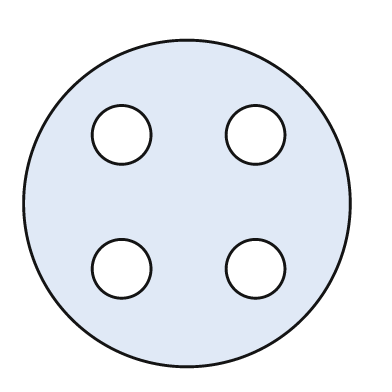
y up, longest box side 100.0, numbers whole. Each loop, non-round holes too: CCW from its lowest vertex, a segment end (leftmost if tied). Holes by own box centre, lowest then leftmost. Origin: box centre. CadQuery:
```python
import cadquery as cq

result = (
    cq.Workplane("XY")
    .moveTo(0.0, 0.0)
    .circle(50.0)
    .moveTo(-20.0, -20.0)
    .circle(9.0)
    .moveTo(21.0, -20.0)
    .circle(9.0)
    .moveTo(-20.0, 21.0)
    .circle(9.0)
    .moveTo(21.0, 21.0)
    .circle(9.0)
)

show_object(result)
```